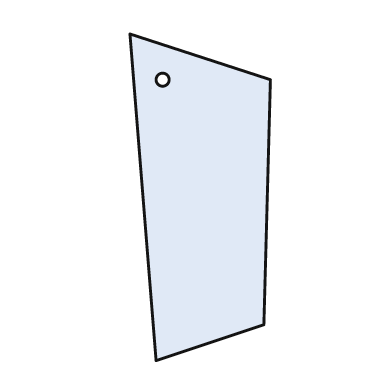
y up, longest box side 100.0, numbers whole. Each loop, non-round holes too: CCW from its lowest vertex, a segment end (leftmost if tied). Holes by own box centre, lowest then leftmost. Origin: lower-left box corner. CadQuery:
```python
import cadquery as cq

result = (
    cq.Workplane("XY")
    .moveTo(8.0, 0.0)
    .lineTo(41.0, 11.0)
    .lineTo(43.0, 86.0)
    .lineTo(0.0, 100.0)
    .close()
    .moveTo(10.0, 86.0)
    .circle(2.0)
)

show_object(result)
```